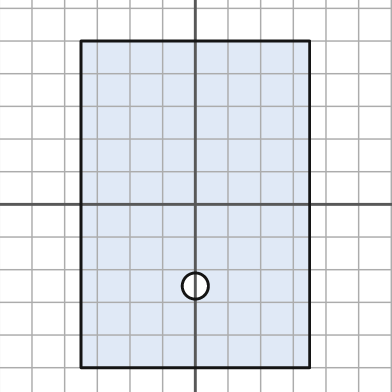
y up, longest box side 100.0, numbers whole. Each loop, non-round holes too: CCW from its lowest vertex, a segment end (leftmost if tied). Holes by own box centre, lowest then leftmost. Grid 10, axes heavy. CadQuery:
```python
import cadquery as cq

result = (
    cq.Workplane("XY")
    .moveTo(-35.0, -50.0)
    .lineTo(35.0, -50.0)
    .lineTo(35.0, 50.0)
    .lineTo(-35.0, 50.0)
    .close()
    .moveTo(0.0, -25.0)
    .circle(4.0)
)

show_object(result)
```